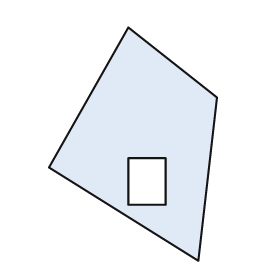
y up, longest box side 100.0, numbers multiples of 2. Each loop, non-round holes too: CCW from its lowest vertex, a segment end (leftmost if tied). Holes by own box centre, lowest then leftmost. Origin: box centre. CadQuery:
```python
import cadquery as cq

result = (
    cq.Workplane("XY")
    .moveTo(28.0, -50.0)
    .lineTo(36.0, 20.0)
    .lineTo(-2.0, 50.0)
    .lineTo(-36.0, -10.0)
    .close()
    .moveTo(-2.0, -26.0)
    .lineTo(14.0, -26.0)
    .lineTo(14.0, -6.0)
    .lineTo(-2.0, -6.0)
    .close()
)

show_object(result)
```